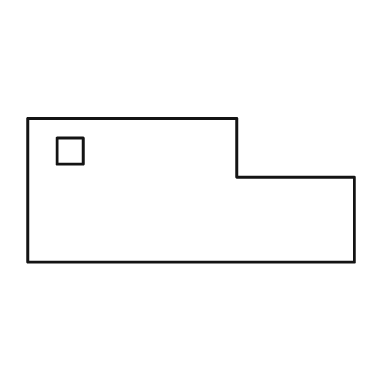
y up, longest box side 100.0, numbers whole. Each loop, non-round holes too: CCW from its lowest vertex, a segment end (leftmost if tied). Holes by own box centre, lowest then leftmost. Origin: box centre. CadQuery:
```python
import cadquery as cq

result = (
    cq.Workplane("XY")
    .moveTo(-50.0, -22.0)
    .lineTo(50.0, -22.0)
    .lineTo(50.0, 4.0)
    .lineTo(14.0, 4.0)
    .lineTo(14.0, 22.0)
    .lineTo(-50.0, 22.0)
    .close()
    .moveTo(-41.0, 8.0)
    .lineTo(-33.0, 8.0)
    .lineTo(-33.0, 16.0)
    .lineTo(-41.0, 16.0)
    .close()
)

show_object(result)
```